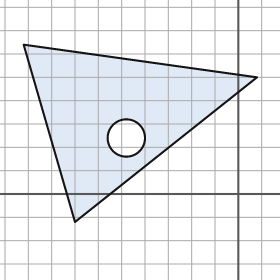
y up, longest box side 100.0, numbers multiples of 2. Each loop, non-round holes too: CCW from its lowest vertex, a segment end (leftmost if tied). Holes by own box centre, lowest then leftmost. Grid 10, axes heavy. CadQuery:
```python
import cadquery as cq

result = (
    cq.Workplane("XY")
    .moveTo(-70.0, -12.0)
    .lineTo(8.0, 50.0)
    .lineTo(-92.0, 64.0)
    .close()
    .moveTo(-48.0, 24.0)
    .circle(8.0)
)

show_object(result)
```